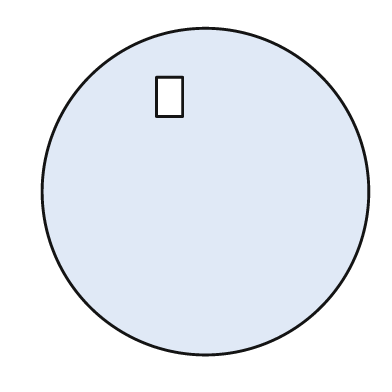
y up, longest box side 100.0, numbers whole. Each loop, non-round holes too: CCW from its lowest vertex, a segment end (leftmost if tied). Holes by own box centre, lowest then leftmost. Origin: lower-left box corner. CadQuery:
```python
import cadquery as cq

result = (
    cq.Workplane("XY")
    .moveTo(50.0, 50.0)
    .circle(50.0)
    .moveTo(35.0, 73.0)
    .lineTo(43.0, 73.0)
    .lineTo(43.0, 85.0)
    .lineTo(35.0, 85.0)
    .close()
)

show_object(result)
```